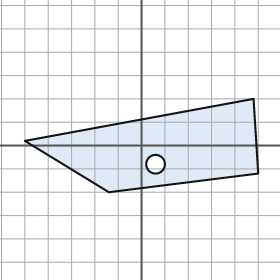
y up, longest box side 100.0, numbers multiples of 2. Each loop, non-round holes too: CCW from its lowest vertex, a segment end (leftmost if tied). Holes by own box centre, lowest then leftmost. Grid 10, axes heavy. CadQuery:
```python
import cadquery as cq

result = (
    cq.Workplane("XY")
    .moveTo(-14.0, -20.0)
    .lineTo(50.0, -12.0)
    .lineTo(48.0, 20.0)
    .lineTo(-50.0, 2.0)
    .close()
    .moveTo(6.0, -8.0)
    .circle(4.0)
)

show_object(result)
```